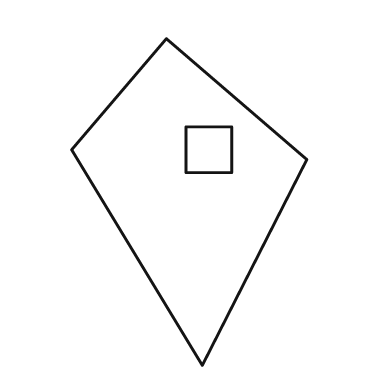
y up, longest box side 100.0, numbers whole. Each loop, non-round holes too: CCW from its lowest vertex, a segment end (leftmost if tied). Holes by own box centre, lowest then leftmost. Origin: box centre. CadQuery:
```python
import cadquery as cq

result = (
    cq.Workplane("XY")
    .moveTo(4.0, -50.0)
    .lineTo(36.0, 13.0)
    .lineTo(-7.0, 50.0)
    .lineTo(-36.0, 16.0)
    .close()
    .moveTo(-1.0, 9.0)
    .lineTo(13.0, 9.0)
    .lineTo(13.0, 23.0)
    .lineTo(-1.0, 23.0)
    .close()
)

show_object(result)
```